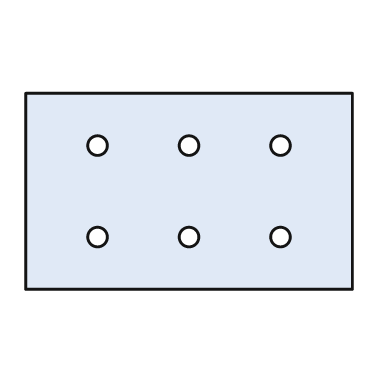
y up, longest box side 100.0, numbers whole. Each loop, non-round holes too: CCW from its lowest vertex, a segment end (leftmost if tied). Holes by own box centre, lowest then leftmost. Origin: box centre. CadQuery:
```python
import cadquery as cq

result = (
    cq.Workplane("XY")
    .moveTo(-50.0, -30.0)
    .lineTo(50.0, -30.0)
    .lineTo(50.0, 30.0)
    .lineTo(-50.0, 30.0)
    .close()
    .moveTo(-28.0, -14.0)
    .circle(3.0)
    .moveTo(0.0, -14.0)
    .circle(3.0)
    .moveTo(28.0, -14.0)
    .circle(3.0)
    .moveTo(-28.0, 14.0)
    .circle(3.0)
    .moveTo(0.0, 14.0)
    .circle(3.0)
    .moveTo(28.0, 14.0)
    .circle(3.0)
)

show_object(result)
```